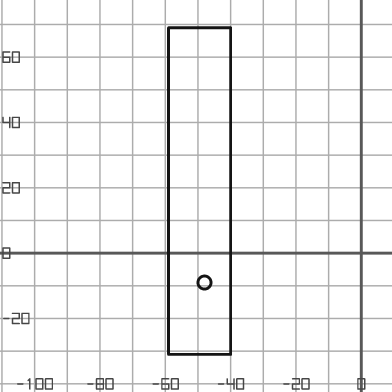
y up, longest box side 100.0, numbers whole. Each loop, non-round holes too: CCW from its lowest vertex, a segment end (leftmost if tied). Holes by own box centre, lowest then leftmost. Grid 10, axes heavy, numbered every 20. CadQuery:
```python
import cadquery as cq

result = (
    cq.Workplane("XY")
    .moveTo(-59.0, -31.0)
    .lineTo(-40.0, -31.0)
    .lineTo(-40.0, 69.0)
    .lineTo(-59.0, 69.0)
    .close()
    .moveTo(-48.0, -9.0)
    .circle(2.0)
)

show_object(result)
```